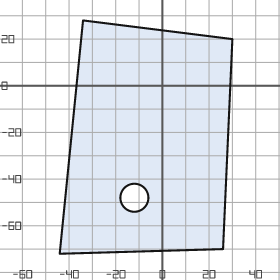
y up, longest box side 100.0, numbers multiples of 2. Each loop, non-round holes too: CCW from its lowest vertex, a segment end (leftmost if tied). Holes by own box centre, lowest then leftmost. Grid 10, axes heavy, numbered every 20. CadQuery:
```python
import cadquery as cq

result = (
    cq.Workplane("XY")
    .moveTo(-44.0, -72.0)
    .lineTo(26.0, -70.0)
    .lineTo(30.0, 20.0)
    .lineTo(-34.0, 28.0)
    .close()
    .moveTo(-12.0, -48.0)
    .circle(6.0)
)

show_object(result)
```